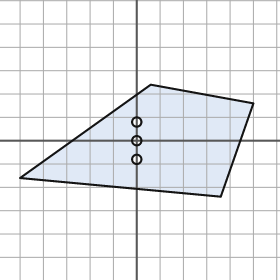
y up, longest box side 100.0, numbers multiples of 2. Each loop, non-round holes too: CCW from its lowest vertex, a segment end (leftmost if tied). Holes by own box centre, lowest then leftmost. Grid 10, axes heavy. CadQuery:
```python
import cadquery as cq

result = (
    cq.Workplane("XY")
    .moveTo(36.0, -24.0)
    .lineTo(50.0, 16.0)
    .lineTo(6.0, 24.0)
    .lineTo(-50.0, -16.0)
    .close()
    .moveTo(0.0, -8.0)
    .circle(2.0)
    .moveTo(0.0, 0.0)
    .circle(2.0)
    .moveTo(0.0, 8.0)
    .circle(2.0)
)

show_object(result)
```